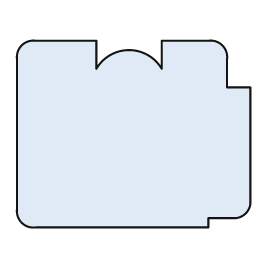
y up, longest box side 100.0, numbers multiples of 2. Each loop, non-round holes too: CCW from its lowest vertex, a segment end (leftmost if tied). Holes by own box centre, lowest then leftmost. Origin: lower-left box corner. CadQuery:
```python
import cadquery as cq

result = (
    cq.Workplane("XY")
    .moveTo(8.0, 0.0)
    .lineTo(82.0, 0.0)
    .lineTo(82.0, 4.0)
    .lineTo(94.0, 4.0)
    .threePointArc((98.0, 6.0), (100.0, 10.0))
    .lineTo(100.0, 60.0)
    .lineTo(90.0, 60.0)
    .lineTo(90.0, 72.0)
    .threePointArc((88.0, 78.0), (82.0, 80.0))
    .lineTo(62.0, 80.0)
    .lineTo(62.0, 68.0)
    .threePointArc((48.0, 76.0), (34.0, 68.0))
    .lineTo(34.0, 80.0)
    .lineTo(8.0, 80.0)
    .threePointArc((2.0, 78.0), (0.0, 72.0))
    .lineTo(0.0, 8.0)
    .threePointArc((2.0, 2.0), (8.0, 0.0))
    .close()
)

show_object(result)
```